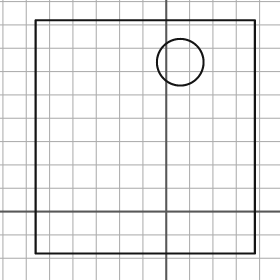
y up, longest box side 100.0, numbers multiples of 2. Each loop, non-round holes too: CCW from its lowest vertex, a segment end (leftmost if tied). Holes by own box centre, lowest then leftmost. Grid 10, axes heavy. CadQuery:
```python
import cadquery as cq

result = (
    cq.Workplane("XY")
    .moveTo(-56.0, -18.0)
    .lineTo(38.0, -18.0)
    .lineTo(38.0, 82.0)
    .lineTo(-56.0, 82.0)
    .close()
    .moveTo(6.0, 64.0)
    .circle(10.0)
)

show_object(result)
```